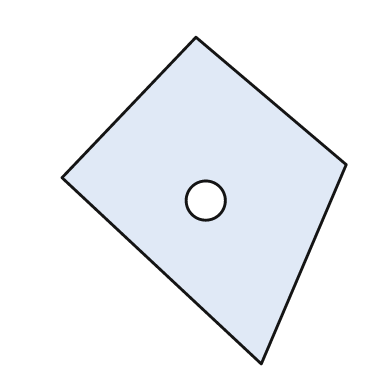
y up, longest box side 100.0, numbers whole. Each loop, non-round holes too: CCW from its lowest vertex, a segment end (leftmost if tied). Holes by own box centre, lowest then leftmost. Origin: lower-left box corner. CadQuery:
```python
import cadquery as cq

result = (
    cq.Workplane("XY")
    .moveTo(61.0, 0.0)
    .lineTo(87.0, 61.0)
    .lineTo(41.0, 100.0)
    .lineTo(0.0, 57.0)
    .close()
    .moveTo(44.0, 50.0)
    .circle(6.0)
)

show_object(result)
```